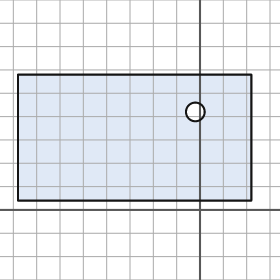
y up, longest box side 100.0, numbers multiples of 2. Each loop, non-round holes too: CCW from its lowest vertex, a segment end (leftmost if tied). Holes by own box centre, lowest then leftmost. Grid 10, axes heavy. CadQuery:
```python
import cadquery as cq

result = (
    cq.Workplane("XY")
    .moveTo(-78.0, 4.0)
    .lineTo(22.0, 4.0)
    .lineTo(22.0, 58.0)
    .lineTo(-78.0, 58.0)
    .close()
    .moveTo(-2.0, 42.0)
    .circle(4.0)
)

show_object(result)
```